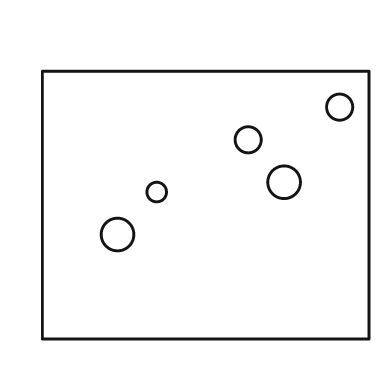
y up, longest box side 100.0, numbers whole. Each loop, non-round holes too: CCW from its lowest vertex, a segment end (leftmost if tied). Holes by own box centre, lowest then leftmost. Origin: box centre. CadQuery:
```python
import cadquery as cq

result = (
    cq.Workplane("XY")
    .moveTo(-50.0, -41.0)
    .lineTo(50.0, -41.0)
    .lineTo(50.0, 41.0)
    .lineTo(-50.0, 41.0)
    .close()
    .moveTo(-27.0, -9.0)
    .circle(5.0)
    .moveTo(-15.0, 4.0)
    .circle(3.0)
    .moveTo(24.0, 7.0)
    .circle(5.0)
    .moveTo(13.0, 20.0)
    .circle(4.0)
    .moveTo(41.0, 30.0)
    .circle(4.0)
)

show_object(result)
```